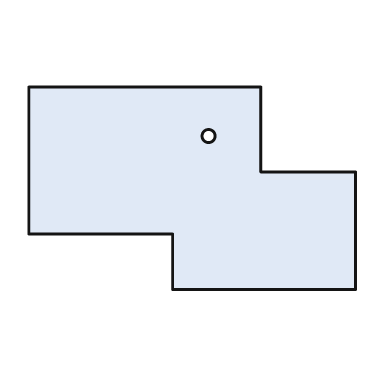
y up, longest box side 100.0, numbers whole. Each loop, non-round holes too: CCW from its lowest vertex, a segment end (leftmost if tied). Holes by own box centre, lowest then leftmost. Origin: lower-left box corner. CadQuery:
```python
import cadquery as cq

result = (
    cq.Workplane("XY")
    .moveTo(44.0, 0.0)
    .lineTo(100.0, 0.0)
    .lineTo(100.0, 36.0)
    .lineTo(71.0, 36.0)
    .lineTo(71.0, 62.0)
    .lineTo(0.0, 62.0)
    .lineTo(0.0, 17.0)
    .lineTo(44.0, 17.0)
    .close()
    .moveTo(55.0, 47.0)
    .circle(2.0)
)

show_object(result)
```